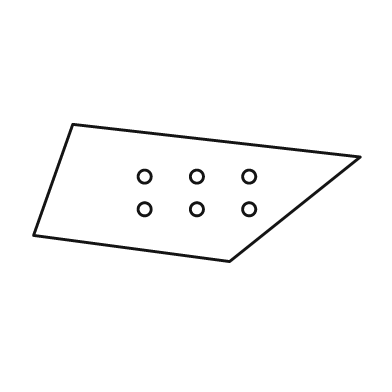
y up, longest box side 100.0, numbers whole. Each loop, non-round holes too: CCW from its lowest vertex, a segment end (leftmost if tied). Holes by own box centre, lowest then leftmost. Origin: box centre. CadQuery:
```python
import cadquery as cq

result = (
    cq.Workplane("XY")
    .moveTo(10.0, -21.0)
    .lineTo(50.0, 11.0)
    .lineTo(-38.0, 21.0)
    .lineTo(-50.0, -13.0)
    .close()
    .moveTo(-16.0, -5.0)
    .circle(2.0)
    .moveTo(0.0, -5.0)
    .circle(2.0)
    .moveTo(16.0, -5.0)
    .circle(2.0)
    .moveTo(-16.0, 5.0)
    .circle(2.0)
    .moveTo(0.0, 5.0)
    .circle(2.0)
    .moveTo(16.0, 5.0)
    .circle(2.0)
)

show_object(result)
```